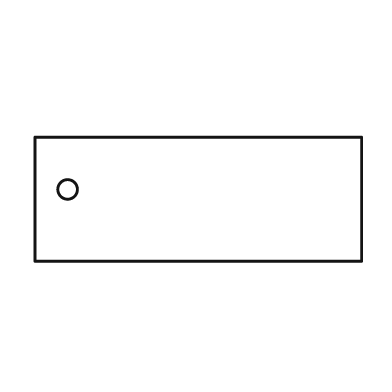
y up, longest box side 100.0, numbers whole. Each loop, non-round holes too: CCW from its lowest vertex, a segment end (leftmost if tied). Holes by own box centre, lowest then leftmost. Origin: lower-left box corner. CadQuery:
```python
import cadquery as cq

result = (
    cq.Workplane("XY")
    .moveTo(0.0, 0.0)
    .lineTo(100.0, 0.0)
    .lineTo(100.0, 38.0)
    .lineTo(0.0, 38.0)
    .close()
    .moveTo(10.0, 22.0)
    .circle(3.0)
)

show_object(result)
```